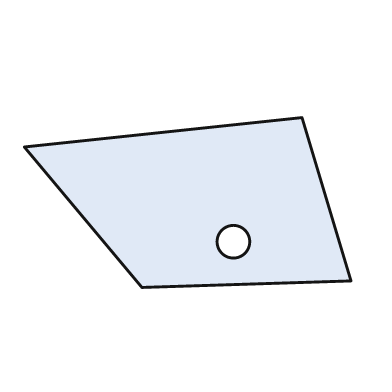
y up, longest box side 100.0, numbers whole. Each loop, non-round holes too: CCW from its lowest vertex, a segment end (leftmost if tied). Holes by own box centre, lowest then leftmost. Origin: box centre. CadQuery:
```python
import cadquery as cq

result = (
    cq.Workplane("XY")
    .moveTo(-14.0, -26.0)
    .lineTo(50.0, -24.0)
    .lineTo(35.0, 26.0)
    .lineTo(-50.0, 17.0)
    .close()
    .moveTo(14.0, -12.0)
    .circle(5.0)
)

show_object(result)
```